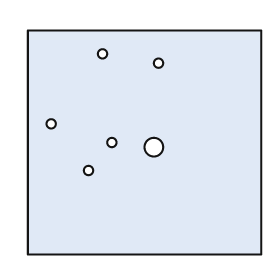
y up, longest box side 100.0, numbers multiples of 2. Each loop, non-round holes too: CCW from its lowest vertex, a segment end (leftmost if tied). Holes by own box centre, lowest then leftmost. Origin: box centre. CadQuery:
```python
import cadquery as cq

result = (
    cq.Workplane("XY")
    .moveTo(-50.0, -48.0)
    .lineTo(50.0, -48.0)
    .lineTo(50.0, 48.0)
    .lineTo(-50.0, 48.0)
    .close()
    .moveTo(-24.0, -12.0)
    .circle(2.0)
    .moveTo(4.0, -2.0)
    .circle(4.0)
    .moveTo(-14.0, 0.0)
    .circle(2.0)
    .moveTo(-40.0, 8.0)
    .circle(2.0)
    .moveTo(6.0, 34.0)
    .circle(2.0)
    .moveTo(-18.0, 38.0)
    .circle(2.0)
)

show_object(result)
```